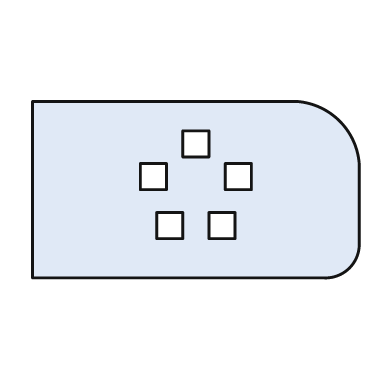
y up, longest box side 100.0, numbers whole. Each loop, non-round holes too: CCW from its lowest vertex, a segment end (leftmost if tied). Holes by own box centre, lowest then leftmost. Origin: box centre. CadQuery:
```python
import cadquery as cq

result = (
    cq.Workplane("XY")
    .moveTo(-50.0, -27.0)
    .lineTo(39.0, -27.0)
    .threePointArc((47.0, -24.0), (50.0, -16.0))
    .lineTo(50.0, 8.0)
    .threePointArc((44.0, 21.0), (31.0, 27.0))
    .lineTo(-50.0, 27.0)
    .close()
    .moveTo(-12.0, -15.0)
    .lineTo(-4.0, -15.0)
    .lineTo(-4.0, -7.0)
    .lineTo(-12.0, -7.0)
    .close()
    .moveTo(4.0, -15.0)
    .lineTo(12.0, -15.0)
    .lineTo(12.0, -7.0)
    .lineTo(4.0, -7.0)
    .close()
    .moveTo(-17.0, 0.0)
    .lineTo(-9.0, 0.0)
    .lineTo(-9.0, 8.0)
    .lineTo(-17.0, 8.0)
    .close()
    .moveTo(9.0, 0.0)
    .lineTo(17.0, 0.0)
    .lineTo(17.0, 8.0)
    .lineTo(9.0, 8.0)
    .close()
    .moveTo(-4.0, 10.0)
    .lineTo(4.0, 10.0)
    .lineTo(4.0, 18.0)
    .lineTo(-4.0, 18.0)
    .close()
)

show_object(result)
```